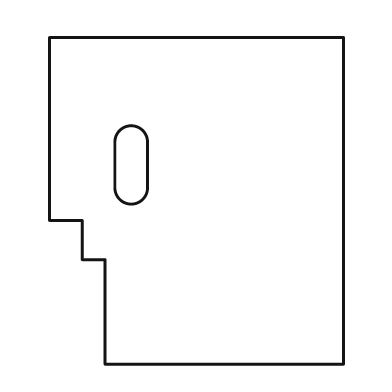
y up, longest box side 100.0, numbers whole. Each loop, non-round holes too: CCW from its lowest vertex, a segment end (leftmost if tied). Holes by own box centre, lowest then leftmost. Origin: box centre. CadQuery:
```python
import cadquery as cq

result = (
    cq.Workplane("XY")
    .moveTo(-28.0, -50.0)
    .lineTo(45.0, -50.0)
    .lineTo(45.0, 50.0)
    .lineTo(-45.0, 50.0)
    .lineTo(-45.0, -6.0)
    .lineTo(-35.0, -6.0)
    .lineTo(-35.0, -18.0)
    .lineTo(-28.0, -18.0)
    .close()
    .moveTo(-25.0, 4.0)
    .threePointArc((-20.0, -1.0), (-15.0, 4.0))
    .lineTo(-15.0, 18.0)
    .threePointArc((-20.0, 23.0), (-25.0, 18.0))
    .close()
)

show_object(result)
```